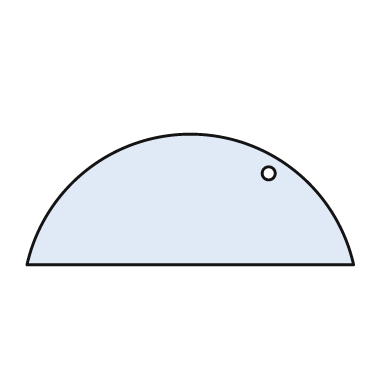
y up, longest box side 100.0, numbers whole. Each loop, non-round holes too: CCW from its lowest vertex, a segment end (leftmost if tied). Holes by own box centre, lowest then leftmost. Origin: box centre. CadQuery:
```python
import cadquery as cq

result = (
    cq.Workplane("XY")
    .moveTo(-50.0, -20.0)
    .lineTo(50.0, -20.0)
    .threePointArc((0.0, 20.0), (-50.0, -20.0))
    .close()
    .moveTo(24.0, 8.0)
    .circle(2.0)
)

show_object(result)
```